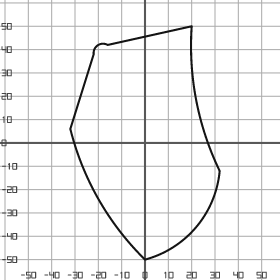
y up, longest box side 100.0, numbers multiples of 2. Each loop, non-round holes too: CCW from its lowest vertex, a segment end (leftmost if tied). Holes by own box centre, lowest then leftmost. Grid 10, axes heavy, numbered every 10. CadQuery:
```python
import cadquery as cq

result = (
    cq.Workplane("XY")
    .moveTo(0.0, -50.0)
    .threePointArc((22.0, -36.0), (32.0, -12.0))
    .threePointArc((22.0, 18.0), (20.0, 50.0))
    .lineTo(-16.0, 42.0)
    .threePointArc((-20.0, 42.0), (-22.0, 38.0))
    .lineTo(-32.0, 6.0)
    .threePointArc((-20.0, -24.0), (0.0, -50.0))
    .close()
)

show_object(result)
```